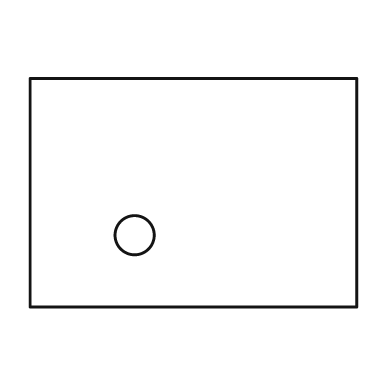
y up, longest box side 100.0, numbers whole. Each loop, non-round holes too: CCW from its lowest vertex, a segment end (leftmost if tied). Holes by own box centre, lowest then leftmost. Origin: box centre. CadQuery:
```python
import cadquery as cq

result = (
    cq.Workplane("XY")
    .moveTo(-50.0, -35.0)
    .lineTo(50.0, -35.0)
    .lineTo(50.0, 35.0)
    .lineTo(-50.0, 35.0)
    .close()
    .moveTo(-18.0, -13.0)
    .circle(6.0)
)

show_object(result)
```